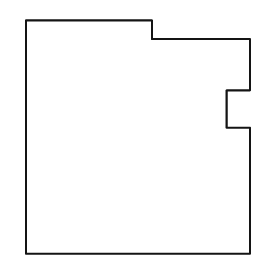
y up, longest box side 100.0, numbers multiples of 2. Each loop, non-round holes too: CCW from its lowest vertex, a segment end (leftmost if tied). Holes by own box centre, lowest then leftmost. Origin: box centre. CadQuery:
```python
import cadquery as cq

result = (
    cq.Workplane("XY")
    .moveTo(-48.0, -50.0)
    .lineTo(48.0, -50.0)
    .lineTo(48.0, 4.0)
    .lineTo(38.0, 4.0)
    .lineTo(38.0, 20.0)
    .lineTo(48.0, 20.0)
    .lineTo(48.0, 42.0)
    .lineTo(6.0, 42.0)
    .lineTo(6.0, 50.0)
    .lineTo(-48.0, 50.0)
    .close()
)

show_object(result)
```